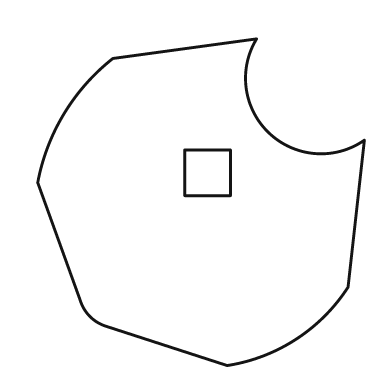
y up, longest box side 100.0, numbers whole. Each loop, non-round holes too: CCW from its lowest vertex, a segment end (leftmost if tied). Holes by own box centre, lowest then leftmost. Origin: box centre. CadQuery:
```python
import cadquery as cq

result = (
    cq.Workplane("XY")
    .moveTo(8.0, -50.0)
    .threePointArc((29.0, -42.0), (45.0, -26.0))
    .lineTo(50.0, 19.0)
    .threePointArc((21.0, 21.0), (17.0, 50.0))
    .lineTo(-27.0, 44.0)
    .threePointArc((-42.0, 27.0), (-50.0, 6.0))
    .lineTo(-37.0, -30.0)
    .threePointArc((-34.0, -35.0), (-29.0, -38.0))
    .close()
    .moveTo(-5.0, 2.0)
    .lineTo(9.0, 2.0)
    .lineTo(9.0, 16.0)
    .lineTo(-5.0, 16.0)
    .close()
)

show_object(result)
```